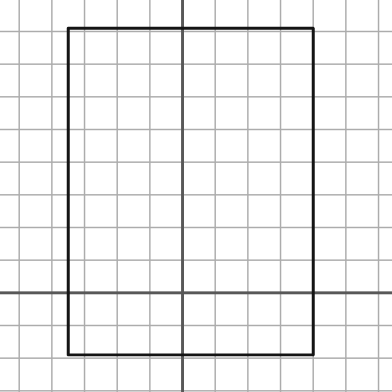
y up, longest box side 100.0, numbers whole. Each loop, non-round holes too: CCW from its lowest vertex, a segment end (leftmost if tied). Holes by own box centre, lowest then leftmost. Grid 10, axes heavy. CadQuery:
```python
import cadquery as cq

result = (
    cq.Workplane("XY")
    .moveTo(-35.0, -19.0)
    .lineTo(40.0, -19.0)
    .lineTo(40.0, 81.0)
    .lineTo(-35.0, 81.0)
    .close()
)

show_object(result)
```